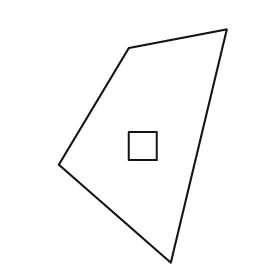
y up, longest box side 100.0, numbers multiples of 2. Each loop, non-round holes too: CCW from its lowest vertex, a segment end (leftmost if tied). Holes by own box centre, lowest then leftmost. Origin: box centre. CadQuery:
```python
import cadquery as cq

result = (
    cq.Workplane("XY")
    .moveTo(12.0, -50.0)
    .lineTo(36.0, 50.0)
    .lineTo(-6.0, 42.0)
    .lineTo(-36.0, -8.0)
    .close()
    .moveTo(-6.0, -6.0)
    .lineTo(6.0, -6.0)
    .lineTo(6.0, 6.0)
    .lineTo(-6.0, 6.0)
    .close()
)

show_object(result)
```